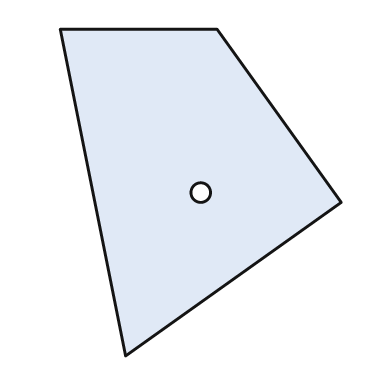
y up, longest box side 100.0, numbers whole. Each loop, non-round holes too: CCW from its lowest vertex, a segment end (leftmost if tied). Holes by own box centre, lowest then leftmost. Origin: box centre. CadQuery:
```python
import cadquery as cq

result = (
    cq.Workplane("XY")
    .moveTo(-23.0, -50.0)
    .lineTo(43.0, -3.0)
    .lineTo(5.0, 50.0)
    .lineTo(-43.0, 50.0)
    .close()
    .moveTo(0.0, 0.0)
    .circle(3.0)
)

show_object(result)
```